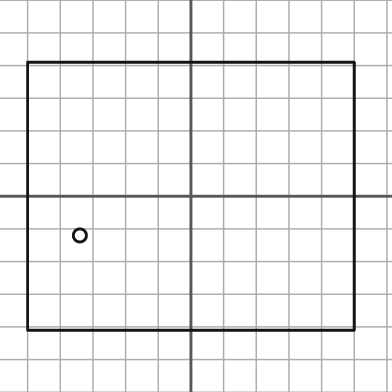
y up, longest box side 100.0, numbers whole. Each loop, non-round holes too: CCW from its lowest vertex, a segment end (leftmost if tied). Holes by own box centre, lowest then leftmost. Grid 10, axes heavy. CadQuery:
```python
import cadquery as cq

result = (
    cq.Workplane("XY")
    .moveTo(-50.0, -41.0)
    .lineTo(50.0, -41.0)
    .lineTo(50.0, 41.0)
    .lineTo(-50.0, 41.0)
    .close()
    .moveTo(-34.0, -12.0)
    .circle(2.0)
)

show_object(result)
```